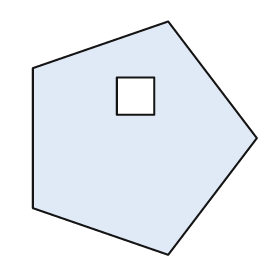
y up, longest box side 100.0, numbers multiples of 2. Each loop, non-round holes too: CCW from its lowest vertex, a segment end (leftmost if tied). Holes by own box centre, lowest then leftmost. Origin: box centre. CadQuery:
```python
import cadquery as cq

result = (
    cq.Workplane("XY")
    .moveTo(10.0, -50.0)
    .lineTo(48.0, 0.0)
    .lineTo(10.0, 50.0)
    .lineTo(-48.0, 30.0)
    .lineTo(-48.0, -30.0)
    .close()
    .moveTo(-12.0, 10.0)
    .lineTo(4.0, 10.0)
    .lineTo(4.0, 26.0)
    .lineTo(-12.0, 26.0)
    .close()
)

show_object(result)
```